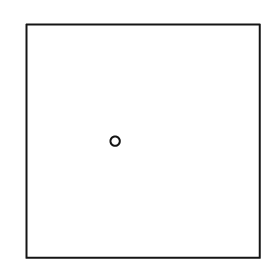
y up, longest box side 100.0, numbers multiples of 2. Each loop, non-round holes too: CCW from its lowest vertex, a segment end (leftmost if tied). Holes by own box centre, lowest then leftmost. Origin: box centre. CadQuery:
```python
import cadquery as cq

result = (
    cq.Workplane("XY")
    .moveTo(-50.0, -50.0)
    .lineTo(50.0, -50.0)
    .lineTo(50.0, 50.0)
    .lineTo(-50.0, 50.0)
    .close()
    .moveTo(-12.0, 0.0)
    .circle(2.0)
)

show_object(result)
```